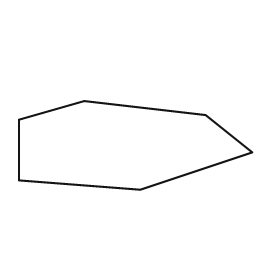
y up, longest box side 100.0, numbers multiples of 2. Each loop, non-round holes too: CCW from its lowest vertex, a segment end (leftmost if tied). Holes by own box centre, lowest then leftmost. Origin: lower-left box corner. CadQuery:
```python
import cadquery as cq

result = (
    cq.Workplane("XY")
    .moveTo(52.0, 0.0)
    .lineTo(100.0, 16.0)
    .lineTo(80.0, 32.0)
    .lineTo(28.0, 38.0)
    .lineTo(0.0, 30.0)
    .lineTo(0.0, 4.0)
    .close()
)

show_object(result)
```